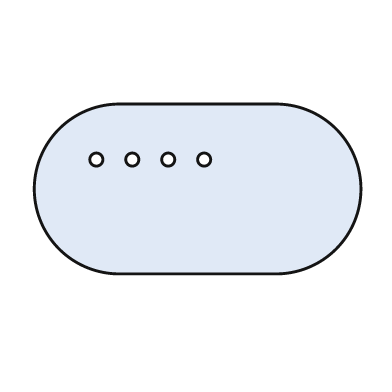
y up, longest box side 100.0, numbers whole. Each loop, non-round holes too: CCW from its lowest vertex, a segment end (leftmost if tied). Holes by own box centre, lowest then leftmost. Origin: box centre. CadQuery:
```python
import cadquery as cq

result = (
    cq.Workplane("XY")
    .moveTo(-24.0, -26.0)
    .lineTo(24.0, -26.0)
    .threePointArc((50.0, 0.0), (24.0, 26.0))
    .lineTo(-24.0, 26.0)
    .threePointArc((-50.0, 0.0), (-24.0, -26.0))
    .close()
    .moveTo(-31.0, 9.0)
    .circle(2.0)
    .moveTo(-20.0, 9.0)
    .circle(2.0)
    .moveTo(-9.0, 9.0)
    .circle(2.0)
    .moveTo(2.0, 9.0)
    .circle(2.0)
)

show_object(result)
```